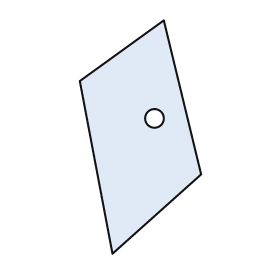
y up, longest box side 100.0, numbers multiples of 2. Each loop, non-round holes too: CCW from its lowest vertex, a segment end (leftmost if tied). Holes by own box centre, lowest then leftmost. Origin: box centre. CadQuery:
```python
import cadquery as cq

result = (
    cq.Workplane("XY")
    .moveTo(-12.0, -50.0)
    .lineTo(26.0, -16.0)
    .lineTo(10.0, 50.0)
    .lineTo(-26.0, 24.0)
    .close()
    .moveTo(6.0, 8.0)
    .circle(4.0)
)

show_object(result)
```